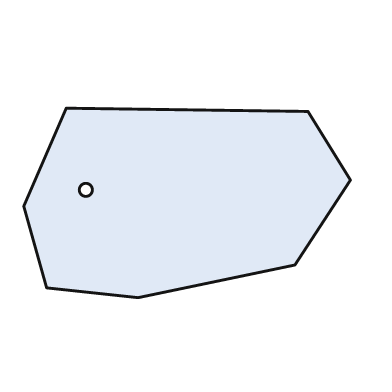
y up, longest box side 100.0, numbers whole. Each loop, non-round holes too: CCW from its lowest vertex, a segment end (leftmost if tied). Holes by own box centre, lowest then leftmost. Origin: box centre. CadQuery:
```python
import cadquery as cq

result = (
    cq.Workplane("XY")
    .moveTo(-15.0, -29.0)
    .lineTo(33.0, -19.0)
    .lineTo(50.0, 7.0)
    .lineTo(37.0, 28.0)
    .lineTo(-37.0, 29.0)
    .lineTo(-50.0, -1.0)
    .lineTo(-43.0, -26.0)
    .close()
    .moveTo(-31.0, 4.0)
    .circle(2.0)
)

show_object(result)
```